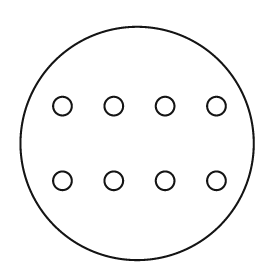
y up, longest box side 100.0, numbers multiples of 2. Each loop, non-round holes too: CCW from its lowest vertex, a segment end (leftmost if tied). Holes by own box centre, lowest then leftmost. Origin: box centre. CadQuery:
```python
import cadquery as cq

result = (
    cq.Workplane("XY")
    .moveTo(0.0, 0.0)
    .circle(50.0)
    .moveTo(-32.0, -16.0)
    .circle(4.0)
    .moveTo(-10.0, -16.0)
    .circle(4.0)
    .moveTo(12.0, -16.0)
    .circle(4.0)
    .moveTo(34.0, -16.0)
    .circle(4.0)
    .moveTo(-32.0, 16.0)
    .circle(4.0)
    .moveTo(-10.0, 16.0)
    .circle(4.0)
    .moveTo(12.0, 16.0)
    .circle(4.0)
    .moveTo(34.0, 16.0)
    .circle(4.0)
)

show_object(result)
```